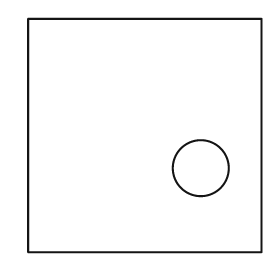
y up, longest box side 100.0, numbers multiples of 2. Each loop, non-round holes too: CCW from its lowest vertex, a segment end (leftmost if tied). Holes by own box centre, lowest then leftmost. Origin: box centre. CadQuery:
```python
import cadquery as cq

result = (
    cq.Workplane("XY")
    .moveTo(-50.0, -50.0)
    .lineTo(50.0, -50.0)
    .lineTo(50.0, 50.0)
    .lineTo(-50.0, 50.0)
    .close()
    .moveTo(24.0, -14.0)
    .circle(12.0)
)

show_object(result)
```